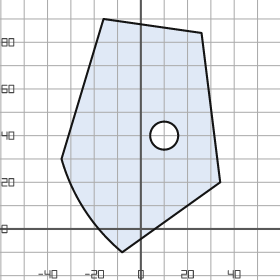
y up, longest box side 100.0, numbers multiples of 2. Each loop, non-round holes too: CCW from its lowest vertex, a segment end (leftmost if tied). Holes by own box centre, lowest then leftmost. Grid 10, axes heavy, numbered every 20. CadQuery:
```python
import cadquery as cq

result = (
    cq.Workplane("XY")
    .moveTo(-8.0, -10.0)
    .lineTo(34.0, 20.0)
    .lineTo(26.0, 84.0)
    .lineTo(-16.0, 90.0)
    .lineTo(-34.0, 30.0)
    .threePointArc((-24.0, 8.0), (-8.0, -10.0))
    .close()
    .moveTo(10.0, 40.0)
    .circle(6.0)
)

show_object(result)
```